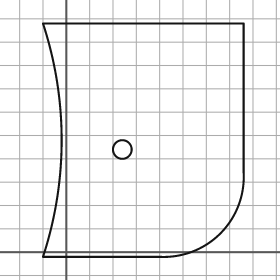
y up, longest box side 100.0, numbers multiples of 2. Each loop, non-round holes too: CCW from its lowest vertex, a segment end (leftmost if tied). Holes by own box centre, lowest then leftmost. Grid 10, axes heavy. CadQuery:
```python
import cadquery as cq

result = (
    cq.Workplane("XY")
    .moveTo(-10.0, -2.0)
    .lineTo(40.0, -2.0)
    .threePointArc((66.0, 8.0), (76.0, 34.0))
    .lineTo(76.0, 98.0)
    .lineTo(-10.0, 98.0)
    .threePointArc((-2.0, 48.0), (-10.0, -2.0))
    .close()
    .moveTo(24.0, 44.0)
    .circle(4.0)
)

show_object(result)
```